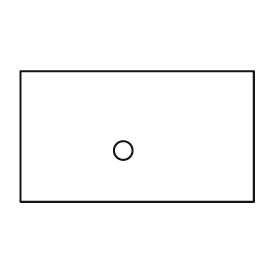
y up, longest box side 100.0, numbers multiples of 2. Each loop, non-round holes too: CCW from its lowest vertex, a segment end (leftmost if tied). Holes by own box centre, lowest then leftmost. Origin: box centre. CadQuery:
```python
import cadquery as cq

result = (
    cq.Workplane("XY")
    .moveTo(-50.0, -28.0)
    .lineTo(50.0, -28.0)
    .lineTo(50.0, 28.0)
    .lineTo(-50.0, 28.0)
    .close()
    .moveTo(-6.0, -6.0)
    .circle(4.0)
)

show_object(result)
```